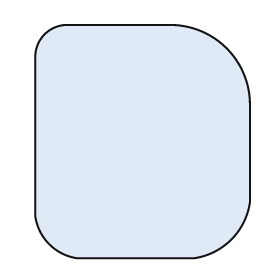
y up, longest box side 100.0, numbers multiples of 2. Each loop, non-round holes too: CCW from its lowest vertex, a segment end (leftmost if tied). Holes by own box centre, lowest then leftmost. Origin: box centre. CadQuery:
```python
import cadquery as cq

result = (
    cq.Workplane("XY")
    .moveTo(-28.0, -50.0)
    .lineTo(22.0, -50.0)
    .threePointArc((38.0, -42.0), (46.0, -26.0))
    .lineTo(46.0, 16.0)
    .threePointArc((36.0, 40.0), (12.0, 50.0))
    .lineTo(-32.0, 50.0)
    .threePointArc((-42.0, 46.0), (-46.0, 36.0))
    .lineTo(-46.0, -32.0)
    .threePointArc((-40.0, -44.0), (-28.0, -50.0))
    .close()
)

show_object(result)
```